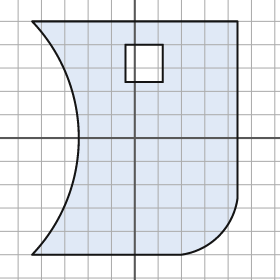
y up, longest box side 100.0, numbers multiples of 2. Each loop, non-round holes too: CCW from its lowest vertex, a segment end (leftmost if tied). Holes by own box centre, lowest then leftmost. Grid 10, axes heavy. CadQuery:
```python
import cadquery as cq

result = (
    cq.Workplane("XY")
    .moveTo(-44.0, -50.0)
    .lineTo(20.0, -50.0)
    .threePointArc((36.0, -42.0), (44.0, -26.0))
    .lineTo(44.0, 50.0)
    .lineTo(-44.0, 50.0)
    .threePointArc((-24.0, 0.0), (-44.0, -50.0))
    .close()
    .moveTo(-4.0, 24.0)
    .lineTo(12.0, 24.0)
    .lineTo(12.0, 40.0)
    .lineTo(-4.0, 40.0)
    .close()
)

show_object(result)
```